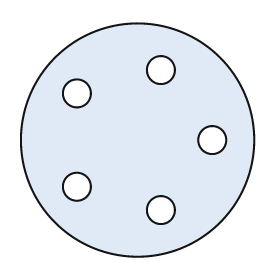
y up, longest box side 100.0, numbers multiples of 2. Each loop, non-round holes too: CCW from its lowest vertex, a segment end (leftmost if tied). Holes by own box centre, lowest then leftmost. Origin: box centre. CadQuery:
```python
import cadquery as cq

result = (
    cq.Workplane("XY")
    .moveTo(0.0, 0.0)
    .circle(50.0)
    .moveTo(10.0, -30.0)
    .circle(6.0)
    .moveTo(-26.0, -20.0)
    .circle(6.0)
    .moveTo(32.0, 0.0)
    .circle(6.0)
    .moveTo(-26.0, 20.0)
    .circle(6.0)
    .moveTo(10.0, 30.0)
    .circle(6.0)
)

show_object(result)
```